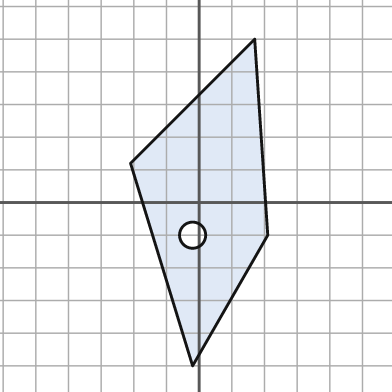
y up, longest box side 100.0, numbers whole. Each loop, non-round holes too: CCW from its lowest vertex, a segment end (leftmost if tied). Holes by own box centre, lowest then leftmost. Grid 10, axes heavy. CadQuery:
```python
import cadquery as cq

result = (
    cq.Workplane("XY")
    .moveTo(-2.0, -50.0)
    .lineTo(21.0, -10.0)
    .lineTo(17.0, 50.0)
    .lineTo(-21.0, 12.0)
    .close()
    .moveTo(-2.0, -10.0)
    .circle(4.0)
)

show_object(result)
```